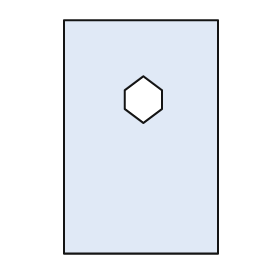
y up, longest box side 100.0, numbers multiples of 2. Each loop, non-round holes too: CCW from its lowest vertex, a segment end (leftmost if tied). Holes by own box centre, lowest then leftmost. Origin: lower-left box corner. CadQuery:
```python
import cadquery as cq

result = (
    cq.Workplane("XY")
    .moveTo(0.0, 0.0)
    .lineTo(66.0, 0.0)
    .lineTo(66.0, 100.0)
    .lineTo(0.0, 100.0)
    .close()
    .moveTo(34.0, 56.0)
    .lineTo(42.0, 62.0)
    .lineTo(42.0, 70.0)
    .lineTo(34.0, 76.0)
    .lineTo(26.0, 70.0)
    .lineTo(26.0, 62.0)
    .close()
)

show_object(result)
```